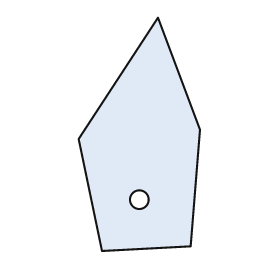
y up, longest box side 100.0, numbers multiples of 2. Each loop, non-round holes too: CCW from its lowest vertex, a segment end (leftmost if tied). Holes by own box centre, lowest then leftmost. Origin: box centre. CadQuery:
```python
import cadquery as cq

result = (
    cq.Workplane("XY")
    .moveTo(-16.0, -50.0)
    .lineTo(22.0, -48.0)
    .lineTo(26.0, 2.0)
    .lineTo(8.0, 50.0)
    .lineTo(-26.0, -2.0)
    .close()
    .moveTo(0.0, -28.0)
    .circle(4.0)
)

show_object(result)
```